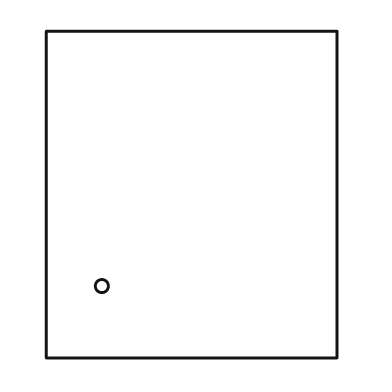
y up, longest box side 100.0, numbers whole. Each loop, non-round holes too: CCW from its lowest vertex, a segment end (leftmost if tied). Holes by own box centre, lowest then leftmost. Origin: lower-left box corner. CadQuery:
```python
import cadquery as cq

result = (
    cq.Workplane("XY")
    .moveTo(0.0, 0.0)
    .lineTo(89.0, 0.0)
    .lineTo(89.0, 100.0)
    .lineTo(0.0, 100.0)
    .close()
    .moveTo(17.0, 22.0)
    .circle(2.0)
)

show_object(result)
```